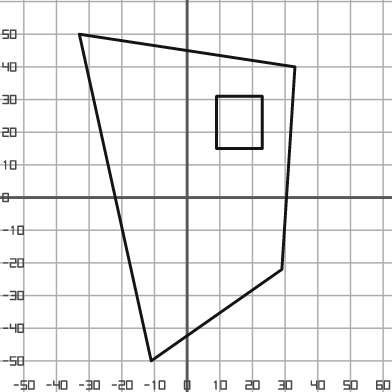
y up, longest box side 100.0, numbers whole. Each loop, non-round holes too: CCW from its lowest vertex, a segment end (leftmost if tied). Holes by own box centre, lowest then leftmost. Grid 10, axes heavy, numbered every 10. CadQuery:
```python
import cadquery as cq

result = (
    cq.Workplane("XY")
    .moveTo(-11.0, -50.0)
    .lineTo(29.0, -22.0)
    .lineTo(33.0, 40.0)
    .lineTo(-33.0, 50.0)
    .close()
    .moveTo(9.0, 15.0)
    .lineTo(23.0, 15.0)
    .lineTo(23.0, 31.0)
    .lineTo(9.0, 31.0)
    .close()
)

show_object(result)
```